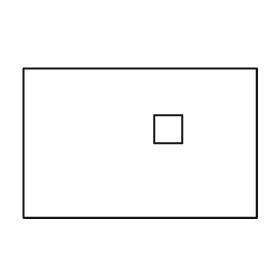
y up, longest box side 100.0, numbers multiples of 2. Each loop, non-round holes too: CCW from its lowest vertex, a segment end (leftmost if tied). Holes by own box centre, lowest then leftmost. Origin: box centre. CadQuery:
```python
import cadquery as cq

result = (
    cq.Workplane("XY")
    .moveTo(-50.0, -32.0)
    .lineTo(50.0, -32.0)
    .lineTo(50.0, 32.0)
    .lineTo(-50.0, 32.0)
    .close()
    .moveTo(6.0, 0.0)
    .lineTo(18.0, 0.0)
    .lineTo(18.0, 12.0)
    .lineTo(6.0, 12.0)
    .close()
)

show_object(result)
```